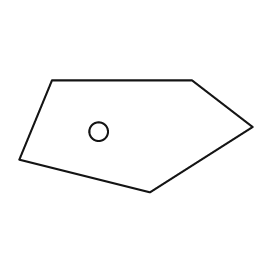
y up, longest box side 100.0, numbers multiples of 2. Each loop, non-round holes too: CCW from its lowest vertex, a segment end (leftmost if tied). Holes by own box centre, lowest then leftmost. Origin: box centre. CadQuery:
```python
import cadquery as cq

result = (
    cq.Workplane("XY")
    .moveTo(6.0, -24.0)
    .lineTo(50.0, 4.0)
    .lineTo(24.0, 24.0)
    .lineTo(-36.0, 24.0)
    .lineTo(-50.0, -10.0)
    .close()
    .moveTo(-16.0, 2.0)
    .circle(4.0)
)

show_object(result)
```